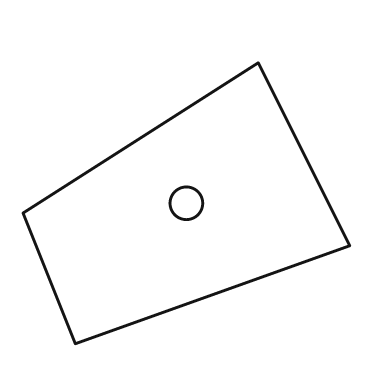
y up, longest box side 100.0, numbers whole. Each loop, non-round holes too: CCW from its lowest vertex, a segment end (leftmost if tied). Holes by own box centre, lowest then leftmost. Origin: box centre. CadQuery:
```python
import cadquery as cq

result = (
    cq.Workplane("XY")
    .moveTo(-34.0, -43.0)
    .lineTo(50.0, -13.0)
    .lineTo(22.0, 43.0)
    .lineTo(-50.0, -3.0)
    .close()
    .moveTo(0.0, 0.0)
    .circle(5.0)
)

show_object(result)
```